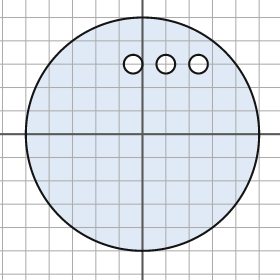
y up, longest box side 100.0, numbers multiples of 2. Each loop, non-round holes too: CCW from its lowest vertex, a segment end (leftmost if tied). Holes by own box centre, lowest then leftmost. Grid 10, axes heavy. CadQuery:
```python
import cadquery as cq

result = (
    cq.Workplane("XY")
    .moveTo(0.0, 0.0)
    .circle(50.0)
    .moveTo(-4.0, 30.0)
    .circle(4.0)
    .moveTo(10.0, 30.0)
    .circle(4.0)
    .moveTo(24.0, 30.0)
    .circle(4.0)
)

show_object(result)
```